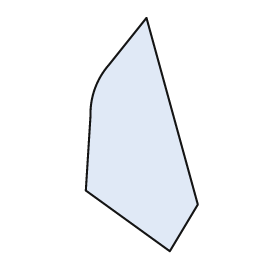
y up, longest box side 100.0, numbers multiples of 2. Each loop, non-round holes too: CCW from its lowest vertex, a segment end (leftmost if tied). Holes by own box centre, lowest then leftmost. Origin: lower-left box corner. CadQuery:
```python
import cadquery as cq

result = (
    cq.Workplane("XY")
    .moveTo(36.0, 0.0)
    .lineTo(48.0, 20.0)
    .lineTo(26.0, 100.0)
    .lineTo(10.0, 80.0)
    .threePointArc((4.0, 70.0), (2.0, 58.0))
    .lineTo(0.0, 26.0)
    .close()
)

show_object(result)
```